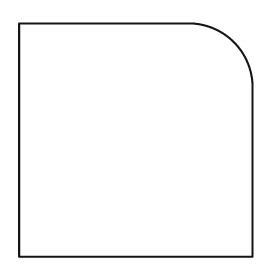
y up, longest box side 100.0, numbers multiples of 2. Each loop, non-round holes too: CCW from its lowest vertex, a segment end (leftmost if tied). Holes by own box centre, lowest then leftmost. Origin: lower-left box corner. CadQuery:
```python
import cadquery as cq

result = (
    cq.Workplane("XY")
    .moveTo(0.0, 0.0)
    .lineTo(100.0, 0.0)
    .lineTo(100.0, 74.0)
    .threePointArc((92.0, 92.0), (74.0, 100.0))
    .lineTo(0.0, 100.0)
    .close()
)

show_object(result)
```